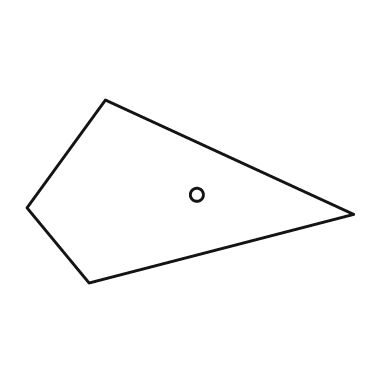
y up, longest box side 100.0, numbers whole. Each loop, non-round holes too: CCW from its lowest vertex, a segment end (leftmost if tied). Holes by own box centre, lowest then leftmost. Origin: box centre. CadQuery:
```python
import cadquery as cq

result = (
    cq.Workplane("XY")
    .moveTo(-31.0, -28.0)
    .lineTo(50.0, -7.0)
    .lineTo(-26.0, 28.0)
    .lineTo(-50.0, -5.0)
    .close()
    .moveTo(2.0, -1.0)
    .circle(2.0)
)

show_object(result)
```